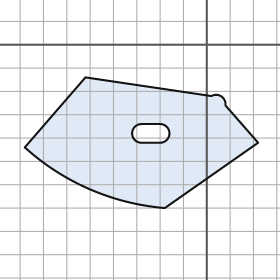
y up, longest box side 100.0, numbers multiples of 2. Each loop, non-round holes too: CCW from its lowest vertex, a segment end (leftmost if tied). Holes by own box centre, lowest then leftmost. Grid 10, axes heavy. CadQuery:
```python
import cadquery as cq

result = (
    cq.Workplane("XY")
    .moveTo(-18.0, -70.0)
    .lineTo(22.0, -42.0)
    .lineTo(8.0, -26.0)
    .threePointArc((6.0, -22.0), (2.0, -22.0))
    .lineTo(-52.0, -14.0)
    .lineTo(-78.0, -44.0)
    .threePointArc((-50.0, -62.0), (-18.0, -70.0))
    .close()
    .moveTo(-28.0, -42.0)
    .lineTo(-20.0, -42.0)
    .threePointArc((-16.0, -38.0), (-20.0, -34.0))
    .lineTo(-28.0, -34.0)
    .threePointArc((-32.0, -38.0), (-28.0, -42.0))
    .close()
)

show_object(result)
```